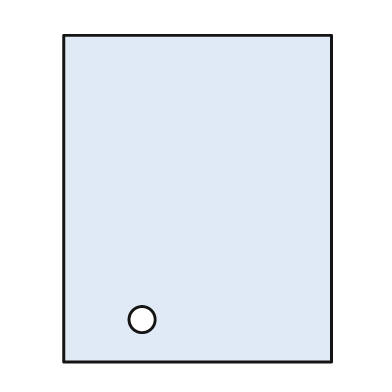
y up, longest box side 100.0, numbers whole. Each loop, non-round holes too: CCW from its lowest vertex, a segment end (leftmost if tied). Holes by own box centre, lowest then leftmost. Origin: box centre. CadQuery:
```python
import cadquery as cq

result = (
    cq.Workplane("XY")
    .moveTo(-41.0, -50.0)
    .lineTo(41.0, -50.0)
    .lineTo(41.0, 50.0)
    .lineTo(-41.0, 50.0)
    .close()
    .moveTo(-17.0, -37.0)
    .circle(4.0)
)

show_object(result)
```